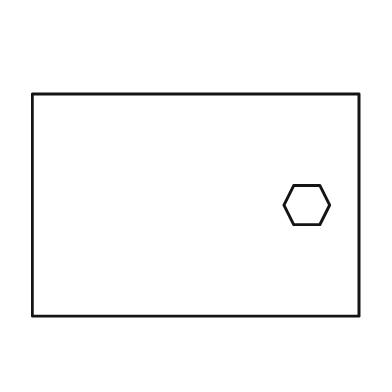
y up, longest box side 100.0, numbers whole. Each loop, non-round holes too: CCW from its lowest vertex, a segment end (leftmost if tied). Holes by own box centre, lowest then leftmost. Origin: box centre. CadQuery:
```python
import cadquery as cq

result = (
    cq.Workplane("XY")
    .moveTo(-50.0, -34.0)
    .lineTo(50.0, -34.0)
    .lineTo(50.0, 34.0)
    .lineTo(-50.0, 34.0)
    .close()
    .moveTo(30.0, -6.0)
    .lineTo(38.0, -6.0)
    .lineTo(41.0, 0.0)
    .lineTo(38.0, 6.0)
    .lineTo(30.0, 6.0)
    .lineTo(27.0, 0.0)
    .close()
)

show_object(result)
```